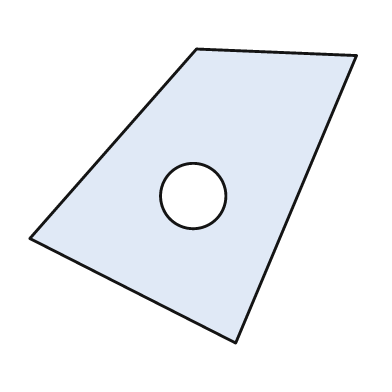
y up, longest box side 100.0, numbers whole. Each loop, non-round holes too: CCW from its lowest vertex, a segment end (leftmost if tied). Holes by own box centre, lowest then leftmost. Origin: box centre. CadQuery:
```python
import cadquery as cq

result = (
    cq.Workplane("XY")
    .moveTo(13.0, -45.0)
    .lineTo(50.0, 43.0)
    .lineTo(1.0, 45.0)
    .lineTo(-50.0, -13.0)
    .close()
    .moveTo(0.0, 0.0)
    .circle(10.0)
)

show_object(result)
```